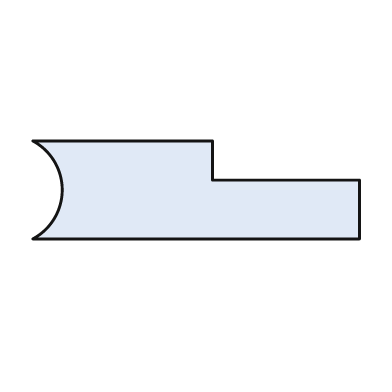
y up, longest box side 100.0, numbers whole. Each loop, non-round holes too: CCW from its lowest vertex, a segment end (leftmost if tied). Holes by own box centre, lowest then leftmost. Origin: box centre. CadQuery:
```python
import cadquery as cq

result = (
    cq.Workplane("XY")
    .moveTo(-50.0, -15.0)
    .lineTo(50.0, -15.0)
    .lineTo(50.0, 3.0)
    .lineTo(5.0, 3.0)
    .lineTo(5.0, 15.0)
    .lineTo(-50.0, 15.0)
    .threePointArc((-41.0, 0.0), (-50.0, -15.0))
    .close()
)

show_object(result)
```